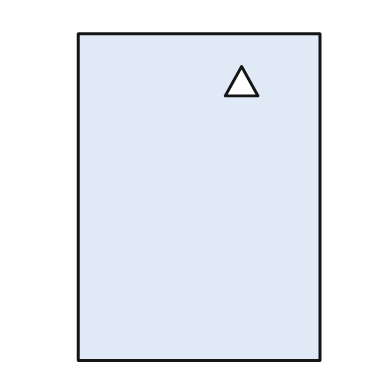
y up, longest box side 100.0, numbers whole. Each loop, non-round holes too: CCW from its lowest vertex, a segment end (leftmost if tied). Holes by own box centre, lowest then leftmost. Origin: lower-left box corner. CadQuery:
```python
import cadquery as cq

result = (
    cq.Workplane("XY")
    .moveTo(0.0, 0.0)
    .lineTo(74.0, 0.0)
    .lineTo(74.0, 100.0)
    .lineTo(0.0, 100.0)
    .close()
    .moveTo(45.0, 81.0)
    .lineTo(55.0, 81.0)
    .lineTo(50.0, 90.0)
    .close()
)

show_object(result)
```